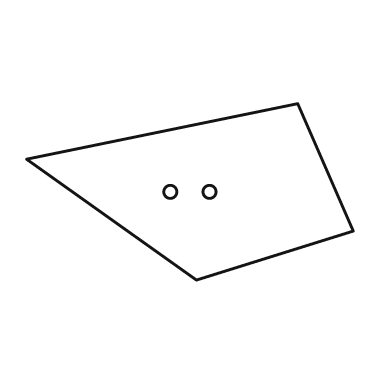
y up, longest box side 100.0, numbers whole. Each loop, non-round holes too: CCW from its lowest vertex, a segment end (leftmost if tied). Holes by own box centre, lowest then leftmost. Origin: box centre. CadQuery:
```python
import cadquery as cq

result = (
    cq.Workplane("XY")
    .moveTo(2.0, -27.0)
    .lineTo(50.0, -12.0)
    .lineTo(33.0, 27.0)
    .lineTo(-50.0, 10.0)
    .close()
    .moveTo(-6.0, 0.0)
    .circle(2.0)
    .moveTo(6.0, 0.0)
    .circle(2.0)
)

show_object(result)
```